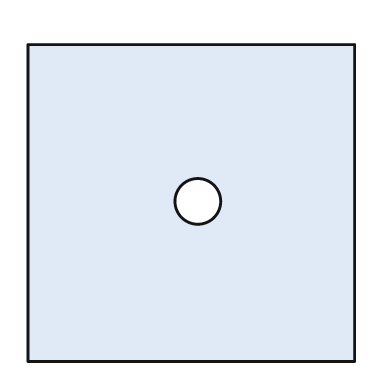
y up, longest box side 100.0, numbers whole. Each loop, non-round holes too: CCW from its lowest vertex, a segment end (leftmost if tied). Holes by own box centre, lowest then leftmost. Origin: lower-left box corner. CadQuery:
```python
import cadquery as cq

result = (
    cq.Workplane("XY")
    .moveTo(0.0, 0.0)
    .lineTo(100.0, 0.0)
    .lineTo(100.0, 97.0)
    .lineTo(0.0, 97.0)
    .close()
    .moveTo(52.0, 49.0)
    .circle(7.0)
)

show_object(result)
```